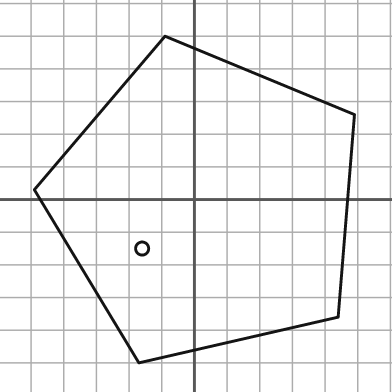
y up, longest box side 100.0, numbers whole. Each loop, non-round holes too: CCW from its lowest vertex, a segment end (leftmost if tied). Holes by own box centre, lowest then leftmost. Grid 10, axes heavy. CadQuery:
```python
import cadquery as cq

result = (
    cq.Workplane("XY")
    .moveTo(-17.0, -50.0)
    .lineTo(44.0, -36.0)
    .lineTo(49.0, 26.0)
    .lineTo(-9.0, 50.0)
    .lineTo(-49.0, 3.0)
    .close()
    .moveTo(-16.0, -15.0)
    .circle(2.0)
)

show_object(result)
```